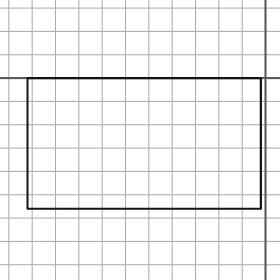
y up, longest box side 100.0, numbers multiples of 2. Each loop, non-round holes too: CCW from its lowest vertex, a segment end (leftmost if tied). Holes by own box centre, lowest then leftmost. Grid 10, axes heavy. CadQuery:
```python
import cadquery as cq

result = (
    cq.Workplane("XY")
    .moveTo(-102.0, -56.0)
    .lineTo(-2.0, -56.0)
    .lineTo(-2.0, 0.0)
    .lineTo(-102.0, 0.0)
    .close()
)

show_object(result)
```